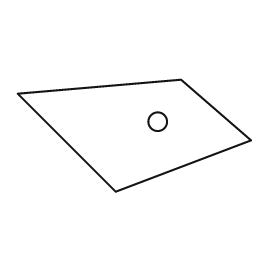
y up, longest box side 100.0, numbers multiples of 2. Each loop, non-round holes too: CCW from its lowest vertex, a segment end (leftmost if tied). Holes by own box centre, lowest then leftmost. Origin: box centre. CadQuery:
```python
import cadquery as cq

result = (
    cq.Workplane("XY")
    .moveTo(-8.0, -24.0)
    .lineTo(50.0, -2.0)
    .lineTo(20.0, 24.0)
    .lineTo(-50.0, 18.0)
    .close()
    .moveTo(10.0, 6.0)
    .circle(4.0)
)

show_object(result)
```